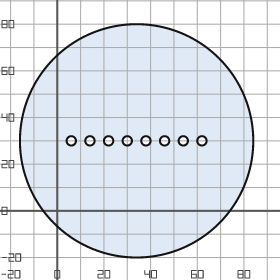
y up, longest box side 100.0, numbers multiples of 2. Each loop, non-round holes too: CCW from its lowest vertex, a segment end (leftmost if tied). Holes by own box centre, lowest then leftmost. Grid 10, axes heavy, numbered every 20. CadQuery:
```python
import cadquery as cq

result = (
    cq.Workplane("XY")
    .moveTo(34.0, 30.0)
    .circle(50.0)
    .moveTo(6.0, 30.0)
    .circle(2.0)
    .moveTo(14.0, 30.0)
    .circle(2.0)
    .moveTo(22.0, 30.0)
    .circle(2.0)
    .moveTo(30.0, 30.0)
    .circle(2.0)
    .moveTo(38.0, 30.0)
    .circle(2.0)
    .moveTo(46.0, 30.0)
    .circle(2.0)
    .moveTo(54.0, 30.0)
    .circle(2.0)
    .moveTo(62.0, 30.0)
    .circle(2.0)
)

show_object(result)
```